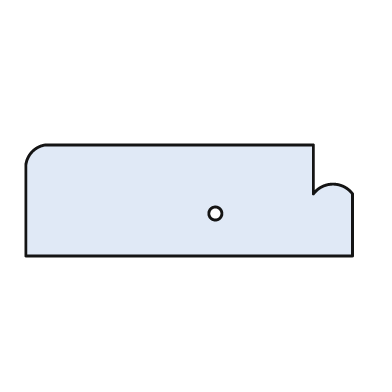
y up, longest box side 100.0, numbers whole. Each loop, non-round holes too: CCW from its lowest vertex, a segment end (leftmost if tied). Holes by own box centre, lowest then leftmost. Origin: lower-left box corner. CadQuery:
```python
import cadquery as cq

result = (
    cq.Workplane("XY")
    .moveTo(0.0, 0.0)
    .lineTo(100.0, 0.0)
    .lineTo(100.0, 19.0)
    .threePointArc((94.0, 22.0), (88.0, 19.0))
    .lineTo(88.0, 34.0)
    .lineTo(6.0, 34.0)
    .threePointArc((2.0, 32.0), (0.0, 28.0))
    .close()
    .moveTo(58.0, 13.0)
    .circle(2.0)
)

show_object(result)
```